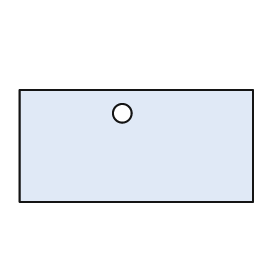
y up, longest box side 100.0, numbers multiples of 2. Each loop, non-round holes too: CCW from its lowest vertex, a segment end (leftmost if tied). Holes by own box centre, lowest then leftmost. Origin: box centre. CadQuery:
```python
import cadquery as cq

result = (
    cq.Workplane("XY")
    .moveTo(-50.0, -24.0)
    .lineTo(50.0, -24.0)
    .lineTo(50.0, 24.0)
    .lineTo(-50.0, 24.0)
    .close()
    .moveTo(-6.0, 14.0)
    .circle(4.0)
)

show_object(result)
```